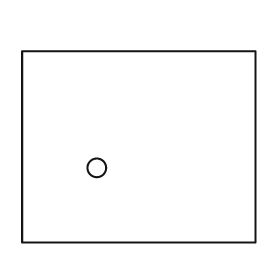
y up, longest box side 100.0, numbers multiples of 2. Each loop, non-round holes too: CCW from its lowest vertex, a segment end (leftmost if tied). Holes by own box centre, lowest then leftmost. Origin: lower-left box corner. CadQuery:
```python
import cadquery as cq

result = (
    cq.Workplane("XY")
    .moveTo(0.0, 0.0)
    .lineTo(100.0, 0.0)
    .lineTo(100.0, 82.0)
    .lineTo(0.0, 82.0)
    .close()
    .moveTo(32.0, 32.0)
    .circle(4.0)
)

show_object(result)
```